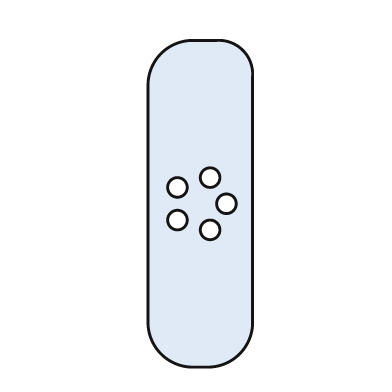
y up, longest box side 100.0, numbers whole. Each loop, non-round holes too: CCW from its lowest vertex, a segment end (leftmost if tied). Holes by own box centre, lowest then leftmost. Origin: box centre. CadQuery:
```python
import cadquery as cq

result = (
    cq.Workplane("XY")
    .moveTo(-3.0, -50.0)
    .lineTo(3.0, -50.0)
    .threePointArc((12.0, -46.0), (16.0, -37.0))
    .lineTo(16.0, 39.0)
    .threePointArc((13.0, 47.0), (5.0, 50.0))
    .lineTo(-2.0, 50.0)
    .threePointArc((-12.0, 46.0), (-16.0, 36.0))
    .lineTo(-16.0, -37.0)
    .threePointArc((-12.0, -46.0), (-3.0, -50.0))
    .close()
    .moveTo(3.0, -8.0)
    .circle(3.0)
    .moveTo(-7.0, -5.0)
    .circle(3.0)
    .moveTo(8.0, 0.0)
    .circle(3.0)
    .moveTo(-7.0, 5.0)
    .circle(3.0)
    .moveTo(3.0, 8.0)
    .circle(3.0)
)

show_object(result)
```